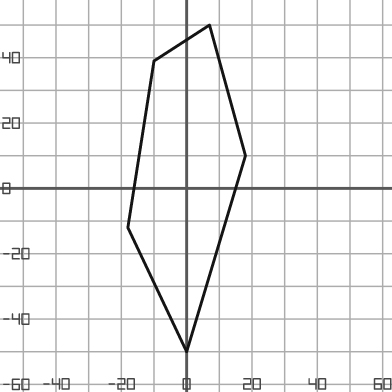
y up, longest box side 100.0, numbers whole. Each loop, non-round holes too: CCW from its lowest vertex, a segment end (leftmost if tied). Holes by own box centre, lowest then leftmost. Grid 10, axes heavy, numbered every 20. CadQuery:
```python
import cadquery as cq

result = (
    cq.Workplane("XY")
    .moveTo(0.0, -50.0)
    .lineTo(18.0, 10.0)
    .lineTo(7.0, 50.0)
    .lineTo(-10.0, 39.0)
    .lineTo(-18.0, -12.0)
    .close()
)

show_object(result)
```